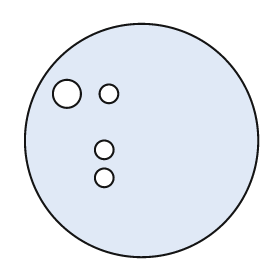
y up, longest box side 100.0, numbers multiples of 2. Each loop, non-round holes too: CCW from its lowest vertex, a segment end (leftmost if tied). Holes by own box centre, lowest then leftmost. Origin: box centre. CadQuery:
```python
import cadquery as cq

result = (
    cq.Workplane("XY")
    .moveTo(0.0, 0.0)
    .circle(50.0)
    .moveTo(-16.0, -16.0)
    .circle(4.0)
    .moveTo(-16.0, -4.0)
    .circle(4.0)
    .moveTo(-32.0, 20.0)
    .circle(6.0)
    .moveTo(-14.0, 20.0)
    .circle(4.0)
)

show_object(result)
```